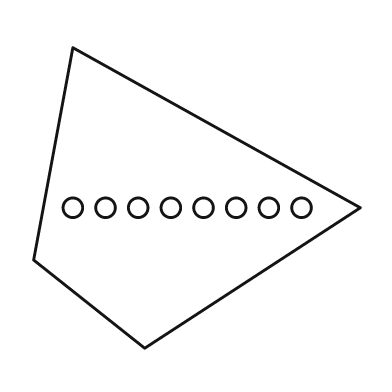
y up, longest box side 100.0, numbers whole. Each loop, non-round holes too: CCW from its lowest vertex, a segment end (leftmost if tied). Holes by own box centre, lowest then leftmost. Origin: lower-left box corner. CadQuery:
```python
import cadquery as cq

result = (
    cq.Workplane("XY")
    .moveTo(34.0, 0.0)
    .lineTo(100.0, 43.0)
    .lineTo(12.0, 92.0)
    .lineTo(0.0, 27.0)
    .close()
    .moveTo(12.0, 43.0)
    .circle(3.0)
    .moveTo(22.0, 43.0)
    .circle(3.0)
    .moveTo(32.0, 43.0)
    .circle(3.0)
    .moveTo(42.0, 43.0)
    .circle(3.0)
    .moveTo(52.0, 43.0)
    .circle(3.0)
    .moveTo(62.0, 43.0)
    .circle(3.0)
    .moveTo(72.0, 43.0)
    .circle(3.0)
    .moveTo(82.0, 43.0)
    .circle(3.0)
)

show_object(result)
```